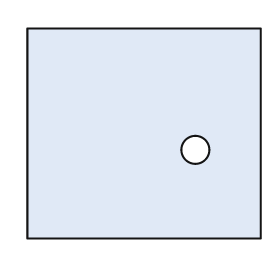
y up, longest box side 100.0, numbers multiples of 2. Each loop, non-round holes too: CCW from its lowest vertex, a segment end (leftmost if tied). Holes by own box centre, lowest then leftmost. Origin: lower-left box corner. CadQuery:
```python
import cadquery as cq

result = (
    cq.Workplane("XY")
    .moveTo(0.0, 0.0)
    .lineTo(100.0, 0.0)
    .lineTo(100.0, 90.0)
    .lineTo(0.0, 90.0)
    .close()
    .moveTo(72.0, 38.0)
    .circle(6.0)
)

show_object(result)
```